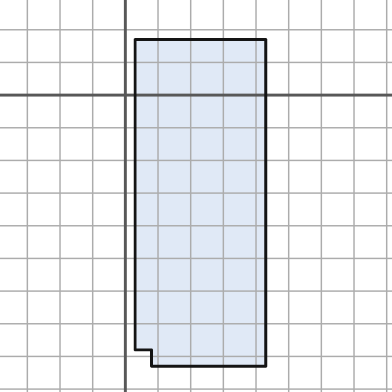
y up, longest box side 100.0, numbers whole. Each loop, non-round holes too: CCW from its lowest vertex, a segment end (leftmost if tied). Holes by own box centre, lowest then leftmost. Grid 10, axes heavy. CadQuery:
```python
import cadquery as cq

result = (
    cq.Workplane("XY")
    .moveTo(8.0, -83.0)
    .lineTo(43.0, -83.0)
    .lineTo(43.0, 17.0)
    .lineTo(3.0, 17.0)
    .lineTo(3.0, -78.0)
    .lineTo(8.0, -78.0)
    .close()
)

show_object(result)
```